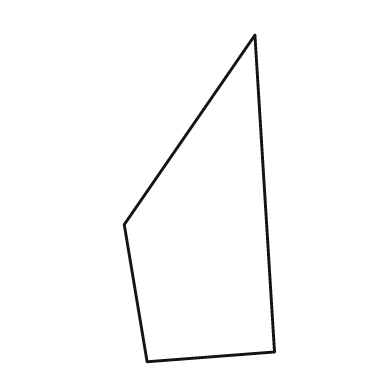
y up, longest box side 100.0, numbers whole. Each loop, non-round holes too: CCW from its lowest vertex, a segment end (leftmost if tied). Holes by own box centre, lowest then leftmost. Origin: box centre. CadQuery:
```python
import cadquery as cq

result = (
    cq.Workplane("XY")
    .moveTo(-16.0, -50.0)
    .lineTo(23.0, -47.0)
    .lineTo(17.0, 50.0)
    .lineTo(-23.0, -8.0)
    .close()
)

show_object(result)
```